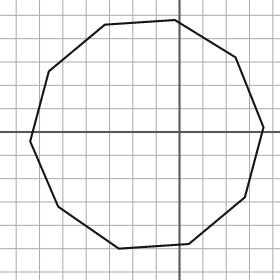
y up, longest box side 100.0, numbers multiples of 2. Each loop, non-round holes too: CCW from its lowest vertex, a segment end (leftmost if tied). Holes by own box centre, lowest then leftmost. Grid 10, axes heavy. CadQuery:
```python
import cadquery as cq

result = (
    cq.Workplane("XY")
    .moveTo(-26.0, -50.0)
    .lineTo(4.0, -48.0)
    .lineTo(28.0, -28.0)
    .lineTo(36.0, 2.0)
    .lineTo(24.0, 32.0)
    .lineTo(-2.0, 48.0)
    .lineTo(-32.0, 46.0)
    .lineTo(-56.0, 26.0)
    .lineTo(-64.0, -4.0)
    .lineTo(-52.0, -32.0)
    .close()
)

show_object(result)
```